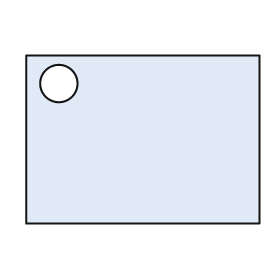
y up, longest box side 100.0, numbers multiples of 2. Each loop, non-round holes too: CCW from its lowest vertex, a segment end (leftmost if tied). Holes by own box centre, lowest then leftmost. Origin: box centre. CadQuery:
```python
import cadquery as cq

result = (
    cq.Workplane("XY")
    .moveTo(-50.0, -36.0)
    .lineTo(50.0, -36.0)
    .lineTo(50.0, 36.0)
    .lineTo(-50.0, 36.0)
    .close()
    .moveTo(-36.0, 24.0)
    .circle(8.0)
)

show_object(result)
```